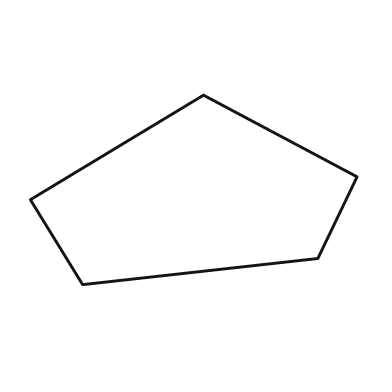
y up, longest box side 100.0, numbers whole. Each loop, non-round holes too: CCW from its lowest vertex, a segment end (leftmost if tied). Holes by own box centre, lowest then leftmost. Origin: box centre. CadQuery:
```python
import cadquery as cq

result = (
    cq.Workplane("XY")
    .moveTo(-34.0, -29.0)
    .lineTo(38.0, -21.0)
    .lineTo(50.0, 4.0)
    .lineTo(3.0, 29.0)
    .lineTo(-50.0, -3.0)
    .close()
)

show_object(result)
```